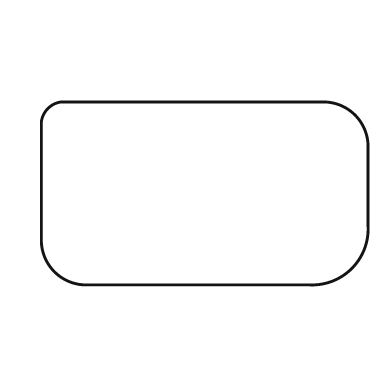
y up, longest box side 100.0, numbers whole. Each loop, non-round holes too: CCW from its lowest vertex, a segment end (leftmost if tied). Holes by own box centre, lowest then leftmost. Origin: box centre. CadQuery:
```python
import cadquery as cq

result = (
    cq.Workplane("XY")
    .moveTo(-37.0, -28.0)
    .lineTo(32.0, -28.0)
    .threePointArc((45.0, -23.0), (50.0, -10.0))
    .lineTo(50.0, 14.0)
    .threePointArc((46.0, 24.0), (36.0, 28.0))
    .lineTo(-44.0, 28.0)
    .threePointArc((-48.0, 26.0), (-50.0, 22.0))
    .lineTo(-50.0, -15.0)
    .threePointArc((-46.0, -24.0), (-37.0, -28.0))
    .close()
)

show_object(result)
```